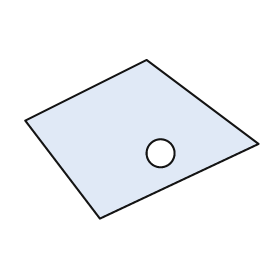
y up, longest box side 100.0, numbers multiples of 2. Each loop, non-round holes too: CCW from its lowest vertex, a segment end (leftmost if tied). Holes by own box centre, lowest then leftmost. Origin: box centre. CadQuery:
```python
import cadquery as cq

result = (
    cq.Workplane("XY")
    .moveTo(-18.0, -34.0)
    .lineTo(50.0, -2.0)
    .lineTo(2.0, 34.0)
    .lineTo(-50.0, 8.0)
    .close()
    .moveTo(8.0, -6.0)
    .circle(6.0)
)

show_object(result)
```